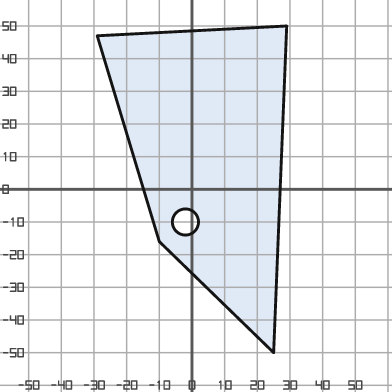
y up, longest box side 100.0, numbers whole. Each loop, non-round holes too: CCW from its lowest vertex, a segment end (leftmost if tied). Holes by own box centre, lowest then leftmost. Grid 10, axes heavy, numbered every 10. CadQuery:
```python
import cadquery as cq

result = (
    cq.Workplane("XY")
    .moveTo(25.0, -50.0)
    .lineTo(29.0, 50.0)
    .lineTo(-29.0, 47.0)
    .lineTo(-10.0, -16.0)
    .close()
    .moveTo(-2.0, -10.0)
    .circle(4.0)
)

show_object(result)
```